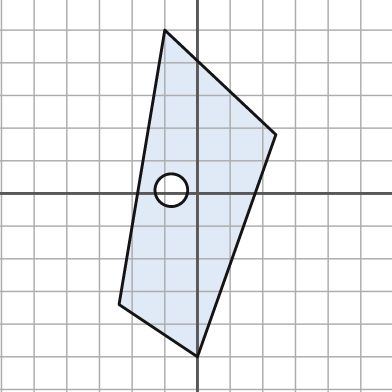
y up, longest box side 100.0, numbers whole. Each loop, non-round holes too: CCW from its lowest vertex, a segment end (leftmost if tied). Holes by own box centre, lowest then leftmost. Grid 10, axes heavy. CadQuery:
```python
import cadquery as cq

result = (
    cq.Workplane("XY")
    .moveTo(0.0, -50.0)
    .lineTo(24.0, 18.0)
    .lineTo(-10.0, 50.0)
    .lineTo(-24.0, -34.0)
    .close()
    .moveTo(-8.0, 1.0)
    .circle(5.0)
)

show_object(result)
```